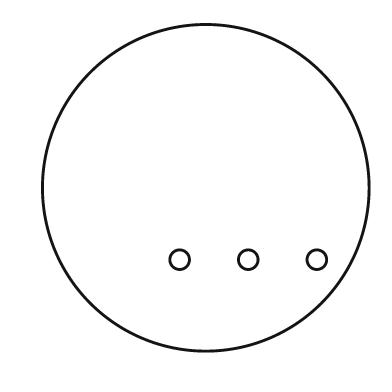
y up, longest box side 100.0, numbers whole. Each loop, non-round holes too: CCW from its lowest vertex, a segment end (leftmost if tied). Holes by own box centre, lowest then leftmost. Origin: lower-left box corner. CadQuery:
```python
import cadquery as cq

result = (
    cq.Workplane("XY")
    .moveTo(50.0, 50.0)
    .circle(50.0)
    .moveTo(42.0, 28.0)
    .circle(3.0)
    .moveTo(63.0, 28.0)
    .circle(3.0)
    .moveTo(84.0, 28.0)
    .circle(3.0)
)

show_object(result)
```